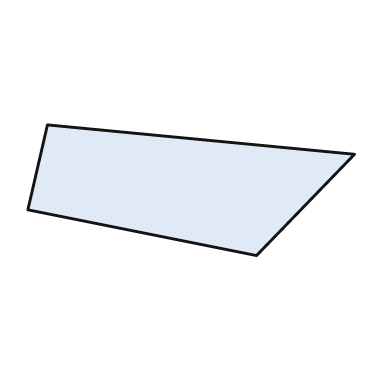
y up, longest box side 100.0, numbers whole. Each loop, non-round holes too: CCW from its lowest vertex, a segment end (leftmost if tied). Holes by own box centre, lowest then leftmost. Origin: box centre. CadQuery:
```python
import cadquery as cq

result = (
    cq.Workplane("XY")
    .moveTo(20.0, -20.0)
    .lineTo(50.0, 11.0)
    .lineTo(-44.0, 20.0)
    .lineTo(-50.0, -6.0)
    .close()
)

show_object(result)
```